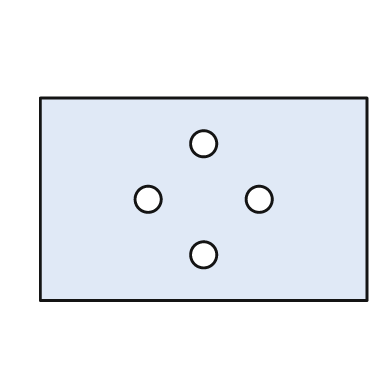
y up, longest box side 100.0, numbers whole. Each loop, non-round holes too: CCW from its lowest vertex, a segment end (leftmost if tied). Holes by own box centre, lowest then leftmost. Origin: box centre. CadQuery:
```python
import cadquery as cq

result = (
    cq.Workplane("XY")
    .moveTo(-50.0, -31.0)
    .lineTo(50.0, -31.0)
    .lineTo(50.0, 31.0)
    .lineTo(-50.0, 31.0)
    .close()
    .moveTo(0.0, -17.0)
    .circle(4.0)
    .moveTo(-17.0, 0.0)
    .circle(4.0)
    .moveTo(17.0, 0.0)
    .circle(4.0)
    .moveTo(0.0, 17.0)
    .circle(4.0)
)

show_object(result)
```